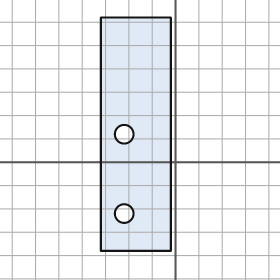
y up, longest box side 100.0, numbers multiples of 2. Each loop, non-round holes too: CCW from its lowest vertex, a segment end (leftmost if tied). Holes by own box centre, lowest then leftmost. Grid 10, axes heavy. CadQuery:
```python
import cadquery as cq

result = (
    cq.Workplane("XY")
    .moveTo(-32.0, -38.0)
    .lineTo(-2.0, -38.0)
    .lineTo(-2.0, 62.0)
    .lineTo(-32.0, 62.0)
    .close()
    .moveTo(-22.0, -22.0)
    .circle(4.0)
    .moveTo(-22.0, 12.0)
    .circle(4.0)
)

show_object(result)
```